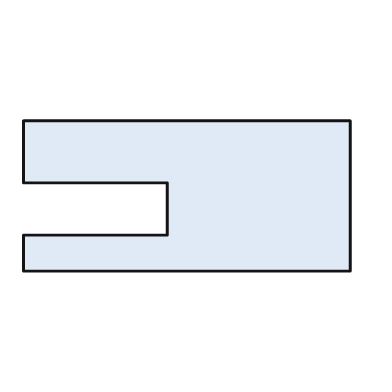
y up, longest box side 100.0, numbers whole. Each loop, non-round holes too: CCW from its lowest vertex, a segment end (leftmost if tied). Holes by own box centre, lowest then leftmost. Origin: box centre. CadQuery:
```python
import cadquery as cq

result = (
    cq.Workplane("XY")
    .moveTo(-50.0, -23.0)
    .lineTo(50.0, -23.0)
    .lineTo(50.0, 23.0)
    .lineTo(-50.0, 23.0)
    .lineTo(-50.0, 4.0)
    .lineTo(-6.0, 4.0)
    .lineTo(-6.0, -12.0)
    .lineTo(-50.0, -12.0)
    .close()
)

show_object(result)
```